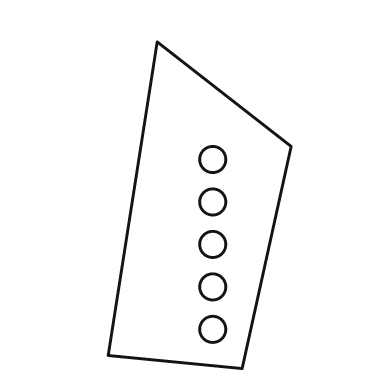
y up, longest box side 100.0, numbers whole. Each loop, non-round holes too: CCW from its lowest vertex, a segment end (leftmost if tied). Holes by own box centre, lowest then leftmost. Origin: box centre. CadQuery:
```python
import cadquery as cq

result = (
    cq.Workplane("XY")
    .moveTo(13.0, -50.0)
    .lineTo(28.0, 18.0)
    .lineTo(-13.0, 50.0)
    .lineTo(-28.0, -46.0)
    .close()
    .moveTo(4.0, -38.0)
    .circle(4.0)
    .moveTo(4.0, -25.0)
    .circle(4.0)
    .moveTo(4.0, -12.0)
    .circle(4.0)
    .moveTo(4.0, 1.0)
    .circle(4.0)
    .moveTo(4.0, 14.0)
    .circle(4.0)
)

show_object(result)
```